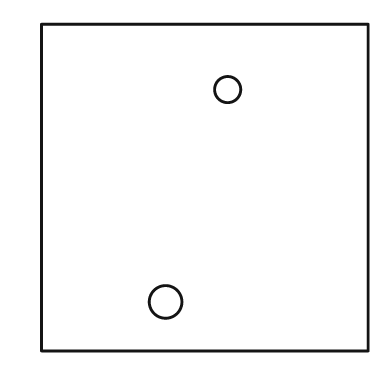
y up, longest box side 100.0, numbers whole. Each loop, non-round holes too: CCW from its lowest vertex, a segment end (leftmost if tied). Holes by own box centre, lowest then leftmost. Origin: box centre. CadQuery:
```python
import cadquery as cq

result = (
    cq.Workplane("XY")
    .moveTo(-50.0, -50.0)
    .lineTo(50.0, -50.0)
    .lineTo(50.0, 50.0)
    .lineTo(-50.0, 50.0)
    .close()
    .moveTo(-12.0, -35.0)
    .circle(5.0)
    .moveTo(7.0, 30.0)
    .circle(4.0)
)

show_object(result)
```